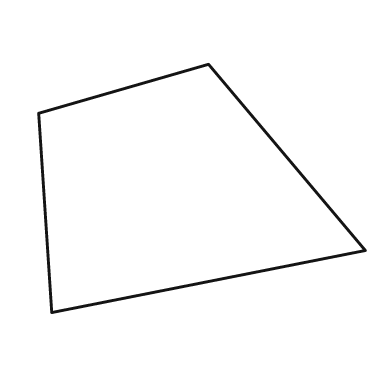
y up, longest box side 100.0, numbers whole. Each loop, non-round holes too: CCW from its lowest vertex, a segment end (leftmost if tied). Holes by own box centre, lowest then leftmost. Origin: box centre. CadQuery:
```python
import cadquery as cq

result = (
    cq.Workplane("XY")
    .moveTo(-46.0, -38.0)
    .lineTo(50.0, -19.0)
    .lineTo(2.0, 38.0)
    .lineTo(-50.0, 23.0)
    .close()
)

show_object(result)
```